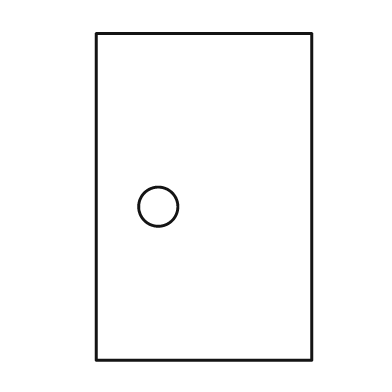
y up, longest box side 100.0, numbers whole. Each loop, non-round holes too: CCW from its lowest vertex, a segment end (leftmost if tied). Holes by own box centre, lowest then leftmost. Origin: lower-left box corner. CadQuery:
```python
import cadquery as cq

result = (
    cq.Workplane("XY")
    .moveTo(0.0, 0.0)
    .lineTo(66.0, 0.0)
    .lineTo(66.0, 100.0)
    .lineTo(0.0, 100.0)
    .close()
    .moveTo(19.0, 47.0)
    .circle(6.0)
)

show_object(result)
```